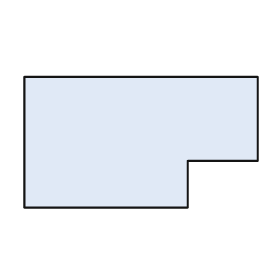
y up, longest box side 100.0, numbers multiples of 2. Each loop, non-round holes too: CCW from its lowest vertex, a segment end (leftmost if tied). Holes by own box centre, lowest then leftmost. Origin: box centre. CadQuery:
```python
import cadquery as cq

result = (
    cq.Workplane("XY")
    .moveTo(-50.0, -28.0)
    .lineTo(20.0, -28.0)
    .lineTo(20.0, -8.0)
    .lineTo(50.0, -8.0)
    .lineTo(50.0, 28.0)
    .lineTo(-50.0, 28.0)
    .close()
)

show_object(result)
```